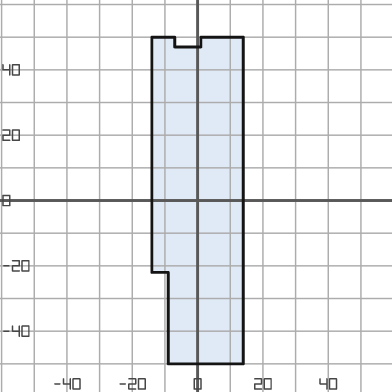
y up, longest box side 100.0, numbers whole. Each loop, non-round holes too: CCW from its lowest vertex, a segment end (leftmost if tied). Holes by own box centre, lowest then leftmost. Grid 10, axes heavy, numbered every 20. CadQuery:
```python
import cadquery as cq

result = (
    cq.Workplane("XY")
    .moveTo(-9.0, -50.0)
    .lineTo(14.0, -50.0)
    .lineTo(14.0, 50.0)
    .lineTo(1.0, 50.0)
    .lineTo(1.0, 47.0)
    .lineTo(-7.0, 47.0)
    .lineTo(-7.0, 50.0)
    .lineTo(-14.0, 50.0)
    .lineTo(-14.0, -22.0)
    .lineTo(-9.0, -22.0)
    .close()
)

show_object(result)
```